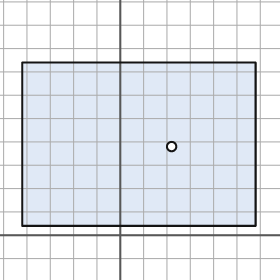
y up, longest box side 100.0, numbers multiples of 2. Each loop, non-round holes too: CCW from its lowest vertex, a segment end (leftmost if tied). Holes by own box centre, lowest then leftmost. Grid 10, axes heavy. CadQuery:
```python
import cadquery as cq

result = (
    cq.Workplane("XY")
    .moveTo(-42.0, 4.0)
    .lineTo(58.0, 4.0)
    .lineTo(58.0, 74.0)
    .lineTo(-42.0, 74.0)
    .close()
    .moveTo(22.0, 38.0)
    .circle(2.0)
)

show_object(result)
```